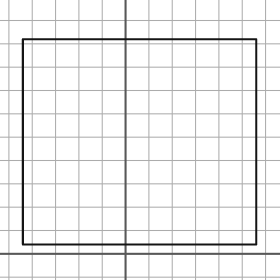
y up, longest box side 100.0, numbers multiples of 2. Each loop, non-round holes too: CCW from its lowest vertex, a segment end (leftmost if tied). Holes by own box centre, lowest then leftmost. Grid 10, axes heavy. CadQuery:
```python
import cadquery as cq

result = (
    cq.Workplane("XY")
    .moveTo(-44.0, 4.0)
    .lineTo(56.0, 4.0)
    .lineTo(56.0, 92.0)
    .lineTo(-44.0, 92.0)
    .close()
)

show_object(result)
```